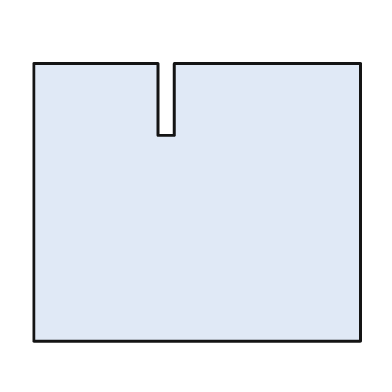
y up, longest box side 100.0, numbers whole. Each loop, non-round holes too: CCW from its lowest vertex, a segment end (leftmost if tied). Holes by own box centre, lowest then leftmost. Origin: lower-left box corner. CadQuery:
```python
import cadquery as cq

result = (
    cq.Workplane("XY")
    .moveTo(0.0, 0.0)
    .lineTo(100.0, 0.0)
    .lineTo(100.0, 85.0)
    .lineTo(43.0, 85.0)
    .lineTo(43.0, 63.0)
    .lineTo(38.0, 63.0)
    .lineTo(38.0, 85.0)
    .lineTo(0.0, 85.0)
    .close()
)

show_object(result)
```